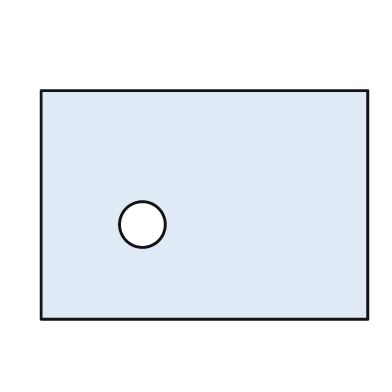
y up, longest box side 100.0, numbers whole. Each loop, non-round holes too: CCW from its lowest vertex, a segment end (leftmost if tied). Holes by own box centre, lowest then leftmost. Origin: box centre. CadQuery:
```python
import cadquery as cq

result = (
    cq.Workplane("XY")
    .moveTo(-50.0, -35.0)
    .lineTo(50.0, -35.0)
    .lineTo(50.0, 35.0)
    .lineTo(-50.0, 35.0)
    .close()
    .moveTo(-19.0, -6.0)
    .circle(7.0)
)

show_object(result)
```